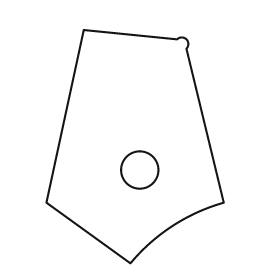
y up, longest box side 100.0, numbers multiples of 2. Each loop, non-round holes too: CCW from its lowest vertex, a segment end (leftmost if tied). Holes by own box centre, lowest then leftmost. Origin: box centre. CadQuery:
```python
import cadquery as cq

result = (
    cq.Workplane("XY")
    .moveTo(-2.0, -50.0)
    .threePointArc((16.0, -34.0), (38.0, -24.0))
    .lineTo(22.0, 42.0)
    .threePointArc((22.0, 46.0), (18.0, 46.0))
    .lineTo(-22.0, 50.0)
    .lineTo(-38.0, -24.0)
    .close()
    .moveTo(2.0, -10.0)
    .circle(8.0)
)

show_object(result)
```